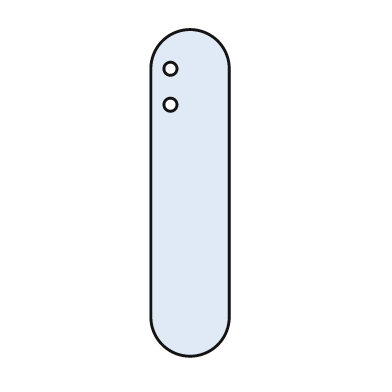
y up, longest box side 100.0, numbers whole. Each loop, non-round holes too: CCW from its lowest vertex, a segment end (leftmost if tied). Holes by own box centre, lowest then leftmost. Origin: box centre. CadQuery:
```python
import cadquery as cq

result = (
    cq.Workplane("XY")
    .moveTo(-12.0, -38.0)
    .threePointArc((0.0, -50.0), (12.0, -38.0))
    .lineTo(12.0, 38.0)
    .threePointArc((0.0, 50.0), (-12.0, 38.0))
    .close()
    .moveTo(-6.0, 27.0)
    .circle(2.0)
    .moveTo(-6.0, 38.0)
    .circle(2.0)
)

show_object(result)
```